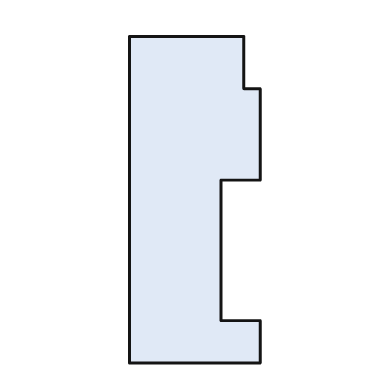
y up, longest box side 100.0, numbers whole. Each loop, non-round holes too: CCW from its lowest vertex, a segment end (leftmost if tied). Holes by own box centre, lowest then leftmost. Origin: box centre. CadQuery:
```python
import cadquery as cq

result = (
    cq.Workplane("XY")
    .moveTo(-20.0, -50.0)
    .lineTo(20.0, -50.0)
    .lineTo(20.0, -37.0)
    .lineTo(8.0, -37.0)
    .lineTo(8.0, 6.0)
    .lineTo(20.0, 6.0)
    .lineTo(20.0, 34.0)
    .lineTo(15.0, 34.0)
    .lineTo(15.0, 50.0)
    .lineTo(-20.0, 50.0)
    .close()
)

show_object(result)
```